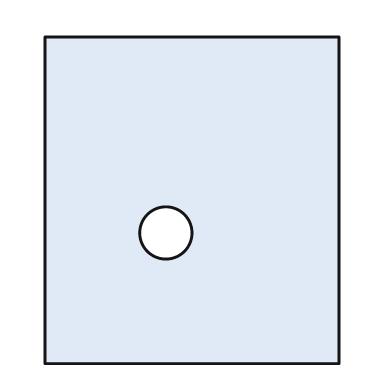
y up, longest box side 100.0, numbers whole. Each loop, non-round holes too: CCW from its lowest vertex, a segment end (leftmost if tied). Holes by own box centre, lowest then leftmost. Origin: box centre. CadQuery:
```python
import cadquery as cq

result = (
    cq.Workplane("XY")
    .moveTo(-45.0, -50.0)
    .lineTo(45.0, -50.0)
    .lineTo(45.0, 50.0)
    .lineTo(-45.0, 50.0)
    .close()
    .moveTo(-8.0, -10.0)
    .circle(8.0)
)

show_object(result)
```